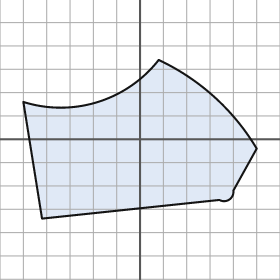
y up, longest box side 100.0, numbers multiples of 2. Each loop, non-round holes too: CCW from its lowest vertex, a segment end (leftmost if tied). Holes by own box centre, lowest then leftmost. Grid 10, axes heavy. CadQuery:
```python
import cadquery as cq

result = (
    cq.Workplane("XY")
    .moveTo(-42.0, -34.0)
    .lineTo(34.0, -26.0)
    .threePointArc((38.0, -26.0), (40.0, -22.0))
    .lineTo(50.0, -4.0)
    .threePointArc((32.0, 18.0), (8.0, 34.0))
    .threePointArc((-18.0, 16.0), (-50.0, 16.0))
    .close()
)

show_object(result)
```